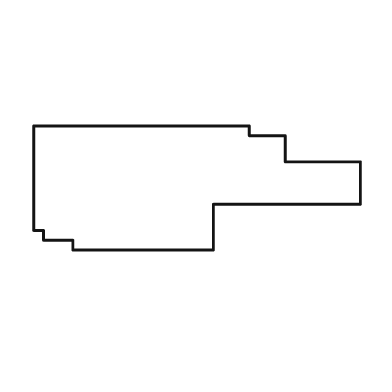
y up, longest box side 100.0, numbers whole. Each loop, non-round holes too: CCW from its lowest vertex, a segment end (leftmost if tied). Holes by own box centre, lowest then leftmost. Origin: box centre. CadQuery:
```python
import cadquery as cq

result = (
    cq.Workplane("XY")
    .moveTo(-38.0, -19.0)
    .lineTo(5.0, -19.0)
    .lineTo(5.0, -5.0)
    .lineTo(50.0, -5.0)
    .lineTo(50.0, 8.0)
    .lineTo(27.0, 8.0)
    .lineTo(27.0, 16.0)
    .lineTo(16.0, 16.0)
    .lineTo(16.0, 19.0)
    .lineTo(-50.0, 19.0)
    .lineTo(-50.0, -13.0)
    .lineTo(-47.0, -13.0)
    .lineTo(-47.0, -16.0)
    .lineTo(-38.0, -16.0)
    .close()
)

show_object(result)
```